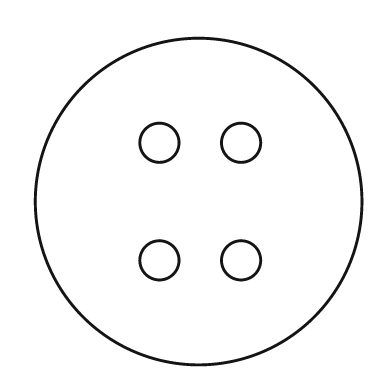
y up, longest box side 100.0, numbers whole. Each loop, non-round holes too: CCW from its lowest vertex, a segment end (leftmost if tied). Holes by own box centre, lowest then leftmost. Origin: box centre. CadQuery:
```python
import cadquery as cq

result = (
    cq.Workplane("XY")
    .moveTo(0.0, 0.0)
    .circle(50.0)
    .moveTo(-12.0, -18.0)
    .circle(6.0)
    .moveTo(13.0, -18.0)
    .circle(6.0)
    .moveTo(-12.0, 18.0)
    .circle(6.0)
    .moveTo(13.0, 18.0)
    .circle(6.0)
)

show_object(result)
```